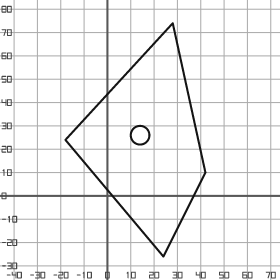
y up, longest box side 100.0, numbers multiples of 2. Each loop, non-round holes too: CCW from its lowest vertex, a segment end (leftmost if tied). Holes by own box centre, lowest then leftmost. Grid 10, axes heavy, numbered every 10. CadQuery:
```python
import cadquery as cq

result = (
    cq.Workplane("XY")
    .moveTo(24.0, -26.0)
    .lineTo(42.0, 10.0)
    .lineTo(28.0, 74.0)
    .lineTo(-18.0, 24.0)
    .close()
    .moveTo(14.0, 26.0)
    .circle(4.0)
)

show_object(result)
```